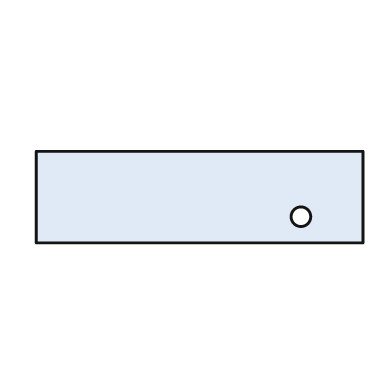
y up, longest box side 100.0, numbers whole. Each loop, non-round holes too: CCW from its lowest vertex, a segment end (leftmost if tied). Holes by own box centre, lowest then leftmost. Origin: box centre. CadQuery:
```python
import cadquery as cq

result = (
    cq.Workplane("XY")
    .moveTo(-50.0, -14.0)
    .lineTo(50.0, -14.0)
    .lineTo(50.0, 14.0)
    .lineTo(-50.0, 14.0)
    .close()
    .moveTo(31.0, -6.0)
    .circle(3.0)
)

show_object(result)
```